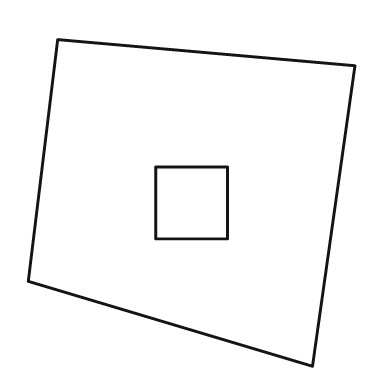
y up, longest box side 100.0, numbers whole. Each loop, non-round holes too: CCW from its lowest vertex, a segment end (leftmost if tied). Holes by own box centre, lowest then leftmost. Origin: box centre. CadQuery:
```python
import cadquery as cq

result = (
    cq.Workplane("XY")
    .moveTo(37.0, -50.0)
    .lineTo(50.0, 42.0)
    .lineTo(-41.0, 50.0)
    .lineTo(-50.0, -24.0)
    .close()
    .moveTo(-11.0, -11.0)
    .lineTo(11.0, -11.0)
    .lineTo(11.0, 11.0)
    .lineTo(-11.0, 11.0)
    .close()
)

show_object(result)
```